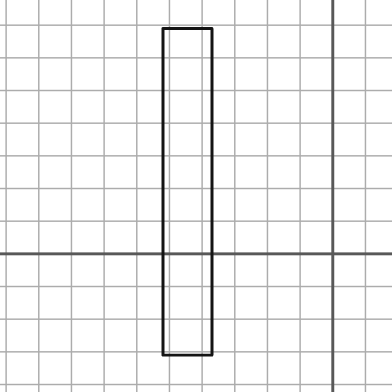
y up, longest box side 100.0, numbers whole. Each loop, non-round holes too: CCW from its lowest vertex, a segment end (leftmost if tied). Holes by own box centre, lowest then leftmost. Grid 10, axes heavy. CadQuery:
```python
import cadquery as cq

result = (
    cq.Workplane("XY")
    .moveTo(-52.0, -31.0)
    .lineTo(-37.0, -31.0)
    .lineTo(-37.0, 69.0)
    .lineTo(-52.0, 69.0)
    .close()
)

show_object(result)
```